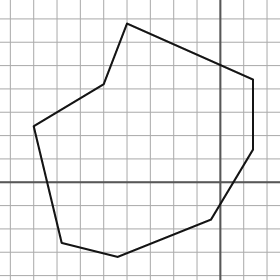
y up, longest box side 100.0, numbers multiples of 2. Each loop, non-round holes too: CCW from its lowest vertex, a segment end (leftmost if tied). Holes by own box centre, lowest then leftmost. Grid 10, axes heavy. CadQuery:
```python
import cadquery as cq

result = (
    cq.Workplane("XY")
    .moveTo(-44.0, -32.0)
    .lineTo(-4.0, -16.0)
    .lineTo(14.0, 14.0)
    .lineTo(14.0, 44.0)
    .lineTo(-40.0, 68.0)
    .lineTo(-50.0, 42.0)
    .lineTo(-80.0, 24.0)
    .lineTo(-68.0, -26.0)
    .close()
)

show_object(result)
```